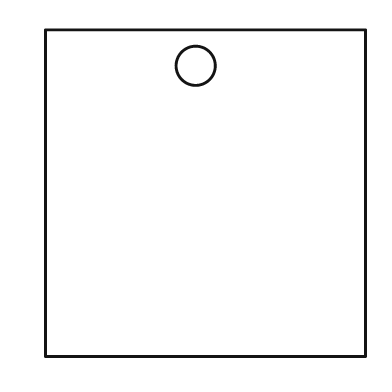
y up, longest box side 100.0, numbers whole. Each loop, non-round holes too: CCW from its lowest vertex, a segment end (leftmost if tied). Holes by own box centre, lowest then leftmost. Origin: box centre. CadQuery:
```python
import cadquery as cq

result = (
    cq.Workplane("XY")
    .moveTo(-49.0, -50.0)
    .lineTo(49.0, -50.0)
    .lineTo(49.0, 50.0)
    .lineTo(-49.0, 50.0)
    .close()
    .moveTo(-3.0, 39.0)
    .circle(6.0)
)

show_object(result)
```